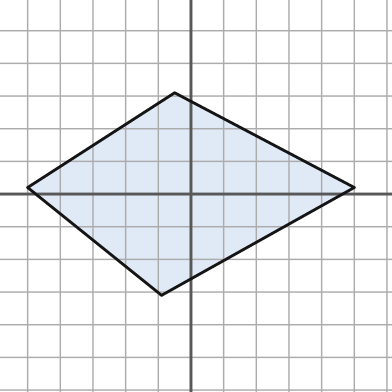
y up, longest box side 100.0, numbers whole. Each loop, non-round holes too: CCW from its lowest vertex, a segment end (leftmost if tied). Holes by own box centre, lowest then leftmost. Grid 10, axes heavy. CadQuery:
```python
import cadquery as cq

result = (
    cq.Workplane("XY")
    .moveTo(-9.0, -31.0)
    .lineTo(50.0, 2.0)
    .lineTo(-5.0, 31.0)
    .lineTo(-50.0, 2.0)
    .close()
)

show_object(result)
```